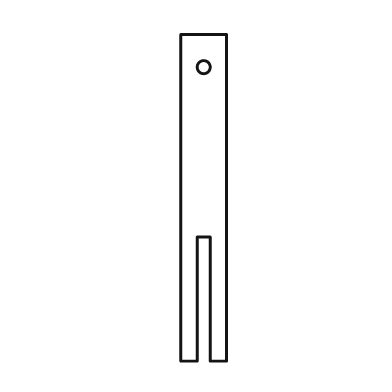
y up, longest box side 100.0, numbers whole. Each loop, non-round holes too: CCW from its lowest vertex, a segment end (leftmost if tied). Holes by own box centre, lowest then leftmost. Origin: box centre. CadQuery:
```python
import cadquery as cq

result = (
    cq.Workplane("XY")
    .moveTo(-7.0, -50.0)
    .lineTo(-2.0, -50.0)
    .lineTo(-2.0, -12.0)
    .lineTo(2.0, -12.0)
    .lineTo(2.0, -50.0)
    .lineTo(7.0, -50.0)
    .lineTo(7.0, 50.0)
    .lineTo(-7.0, 50.0)
    .close()
    .moveTo(0.0, 40.0)
    .circle(2.0)
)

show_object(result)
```